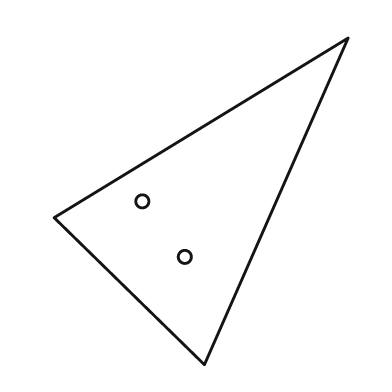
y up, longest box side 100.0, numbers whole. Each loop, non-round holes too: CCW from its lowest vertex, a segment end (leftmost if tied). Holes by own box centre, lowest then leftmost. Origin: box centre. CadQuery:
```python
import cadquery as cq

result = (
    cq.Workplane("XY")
    .moveTo(1.0, -50.0)
    .lineTo(45.0, 50.0)
    .lineTo(-45.0, -5.0)
    .close()
    .moveTo(-5.0, -17.0)
    .circle(2.0)
    .moveTo(-18.0, 0.0)
    .circle(2.0)
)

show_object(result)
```